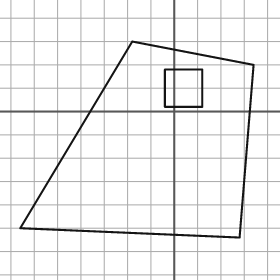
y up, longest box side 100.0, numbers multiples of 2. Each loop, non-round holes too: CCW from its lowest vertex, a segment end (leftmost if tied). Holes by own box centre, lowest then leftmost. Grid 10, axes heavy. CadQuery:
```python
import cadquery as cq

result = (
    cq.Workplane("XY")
    .moveTo(28.0, -54.0)
    .lineTo(34.0, 20.0)
    .lineTo(-18.0, 30.0)
    .lineTo(-66.0, -50.0)
    .close()
    .moveTo(-4.0, 2.0)
    .lineTo(12.0, 2.0)
    .lineTo(12.0, 18.0)
    .lineTo(-4.0, 18.0)
    .close()
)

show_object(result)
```